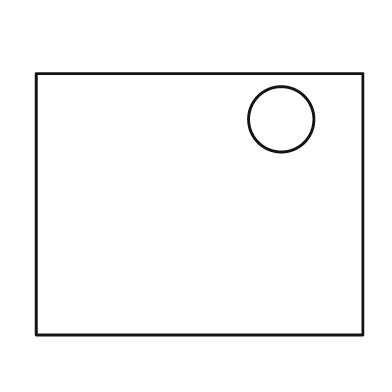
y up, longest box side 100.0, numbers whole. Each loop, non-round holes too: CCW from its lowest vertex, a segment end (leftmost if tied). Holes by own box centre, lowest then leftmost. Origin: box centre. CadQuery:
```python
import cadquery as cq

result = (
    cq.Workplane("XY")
    .moveTo(-50.0, -40.0)
    .lineTo(50.0, -40.0)
    .lineTo(50.0, 40.0)
    .lineTo(-50.0, 40.0)
    .close()
    .moveTo(25.0, 26.0)
    .circle(10.0)
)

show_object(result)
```